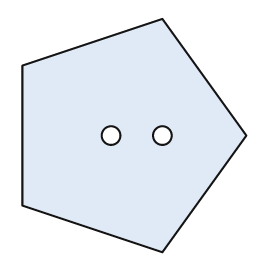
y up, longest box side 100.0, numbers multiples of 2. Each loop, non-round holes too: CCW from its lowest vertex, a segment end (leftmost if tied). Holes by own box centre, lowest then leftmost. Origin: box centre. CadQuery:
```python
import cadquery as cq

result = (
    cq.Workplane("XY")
    .moveTo(12.0, -50.0)
    .lineTo(48.0, 0.0)
    .lineTo(12.0, 50.0)
    .lineTo(-48.0, 30.0)
    .lineTo(-48.0, -30.0)
    .close()
    .moveTo(-10.0, 0.0)
    .circle(4.0)
    .moveTo(12.0, 0.0)
    .circle(4.0)
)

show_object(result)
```